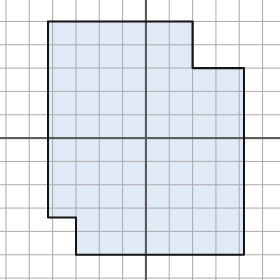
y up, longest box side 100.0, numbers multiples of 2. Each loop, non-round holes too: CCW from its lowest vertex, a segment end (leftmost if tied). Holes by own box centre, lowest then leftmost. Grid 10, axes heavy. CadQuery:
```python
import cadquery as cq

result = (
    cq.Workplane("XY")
    .moveTo(-30.0, -50.0)
    .lineTo(42.0, -50.0)
    .lineTo(42.0, 30.0)
    .lineTo(20.0, 30.0)
    .lineTo(20.0, 50.0)
    .lineTo(-42.0, 50.0)
    .lineTo(-42.0, -34.0)
    .lineTo(-30.0, -34.0)
    .close()
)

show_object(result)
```